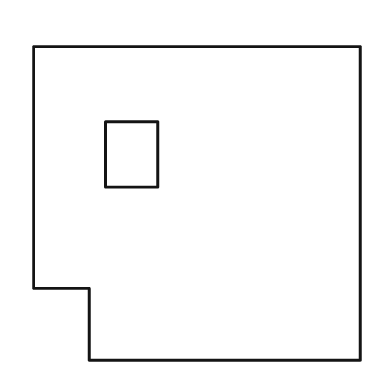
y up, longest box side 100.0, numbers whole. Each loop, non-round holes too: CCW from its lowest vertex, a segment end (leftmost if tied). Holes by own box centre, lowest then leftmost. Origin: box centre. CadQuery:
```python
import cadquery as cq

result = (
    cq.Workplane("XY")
    .moveTo(-33.0, -48.0)
    .lineTo(50.0, -48.0)
    .lineTo(50.0, 48.0)
    .lineTo(-50.0, 48.0)
    .lineTo(-50.0, -26.0)
    .lineTo(-33.0, -26.0)
    .close()
    .moveTo(-28.0, 5.0)
    .lineTo(-12.0, 5.0)
    .lineTo(-12.0, 25.0)
    .lineTo(-28.0, 25.0)
    .close()
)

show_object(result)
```